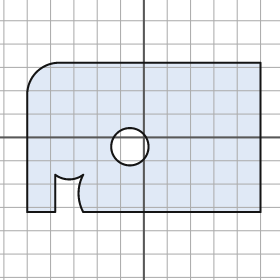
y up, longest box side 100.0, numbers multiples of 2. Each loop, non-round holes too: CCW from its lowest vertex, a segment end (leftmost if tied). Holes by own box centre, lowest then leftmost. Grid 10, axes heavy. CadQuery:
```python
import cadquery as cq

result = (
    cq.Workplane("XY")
    .moveTo(-50.0, -32.0)
    .lineTo(-38.0, -32.0)
    .lineTo(-38.0, -16.0)
    .threePointArc((-32.0, -18.0), (-26.0, -16.0))
    .threePointArc((-28.0, -24.0), (-26.0, -32.0))
    .lineTo(50.0, -32.0)
    .lineTo(50.0, 32.0)
    .lineTo(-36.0, 32.0)
    .threePointArc((-46.0, 28.0), (-50.0, 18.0))
    .close()
    .moveTo(-6.0, -4.0)
    .circle(8.0)
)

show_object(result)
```